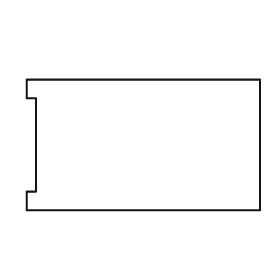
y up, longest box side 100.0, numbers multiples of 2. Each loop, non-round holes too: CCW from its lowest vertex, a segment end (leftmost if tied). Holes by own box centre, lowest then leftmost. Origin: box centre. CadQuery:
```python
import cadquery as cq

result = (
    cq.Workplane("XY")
    .moveTo(-50.0, -28.0)
    .lineTo(50.0, -28.0)
    .lineTo(50.0, 28.0)
    .lineTo(-50.0, 28.0)
    .lineTo(-50.0, 20.0)
    .lineTo(-46.0, 20.0)
    .lineTo(-46.0, -20.0)
    .lineTo(-50.0, -20.0)
    .close()
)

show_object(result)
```